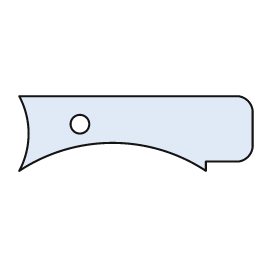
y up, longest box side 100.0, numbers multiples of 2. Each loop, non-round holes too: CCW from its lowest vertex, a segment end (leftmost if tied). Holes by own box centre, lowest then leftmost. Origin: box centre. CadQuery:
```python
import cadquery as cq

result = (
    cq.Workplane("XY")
    .moveTo(-50.0, -16.0)
    .threePointArc((-10.0, -4.0), (30.0, -16.0))
    .lineTo(30.0, -12.0)
    .lineTo(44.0, -12.0)
    .threePointArc((48.0, -10.0), (50.0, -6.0))
    .lineTo(50.0, 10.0)
    .threePointArc((48.0, 14.0), (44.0, 16.0))
    .lineTo(-50.0, 16.0)
    .threePointArc((-46.0, 0.0), (-50.0, -16.0))
    .close()
    .moveTo(-24.0, 4.0)
    .circle(4.0)
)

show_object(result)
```